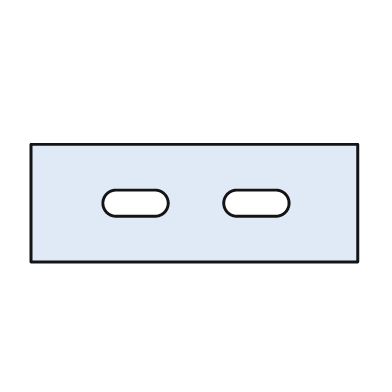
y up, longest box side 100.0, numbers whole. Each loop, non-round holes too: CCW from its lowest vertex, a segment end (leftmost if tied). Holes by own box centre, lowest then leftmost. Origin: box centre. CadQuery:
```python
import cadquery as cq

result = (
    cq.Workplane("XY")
    .moveTo(-50.0, -18.0)
    .lineTo(50.0, -18.0)
    .lineTo(50.0, 18.0)
    .lineTo(-50.0, 18.0)
    .close()
    .moveTo(-24.0, -4.0)
    .lineTo(-12.0, -4.0)
    .threePointArc((-8.0, 0.0), (-12.0, 4.0))
    .lineTo(-24.0, 4.0)
    .threePointArc((-28.0, 0.0), (-24.0, -4.0))
    .close()
    .moveTo(13.0, -4.0)
    .lineTo(25.0, -4.0)
    .threePointArc((29.0, 0.0), (25.0, 4.0))
    .lineTo(13.0, 4.0)
    .threePointArc((9.0, 0.0), (13.0, -4.0))
    .close()
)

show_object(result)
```